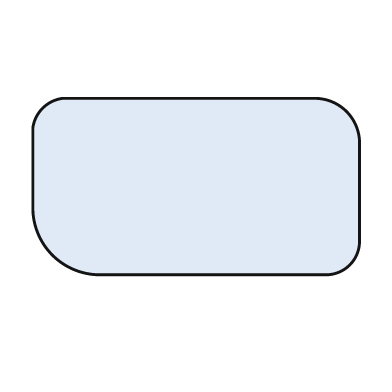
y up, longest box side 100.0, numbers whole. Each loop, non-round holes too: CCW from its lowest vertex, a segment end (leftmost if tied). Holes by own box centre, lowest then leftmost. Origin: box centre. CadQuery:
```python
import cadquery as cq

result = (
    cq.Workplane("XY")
    .moveTo(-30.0, -27.0)
    .lineTo(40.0, -27.0)
    .threePointArc((47.0, -24.0), (50.0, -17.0))
    .lineTo(50.0, 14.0)
    .threePointArc((46.0, 23.0), (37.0, 27.0))
    .lineTo(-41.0, 27.0)
    .threePointArc((-47.0, 24.0), (-50.0, 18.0))
    .lineTo(-50.0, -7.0)
    .threePointArc((-44.0, -21.0), (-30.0, -27.0))
    .close()
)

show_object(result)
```